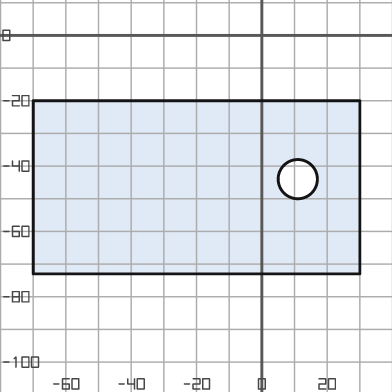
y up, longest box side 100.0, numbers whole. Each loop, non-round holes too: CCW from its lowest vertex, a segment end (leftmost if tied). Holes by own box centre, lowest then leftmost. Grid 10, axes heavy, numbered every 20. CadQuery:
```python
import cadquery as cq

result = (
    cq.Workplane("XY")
    .moveTo(-70.0, -73.0)
    .lineTo(30.0, -73.0)
    .lineTo(30.0, -20.0)
    .lineTo(-70.0, -20.0)
    .close()
    .moveTo(11.0, -44.0)
    .circle(6.0)
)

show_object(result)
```